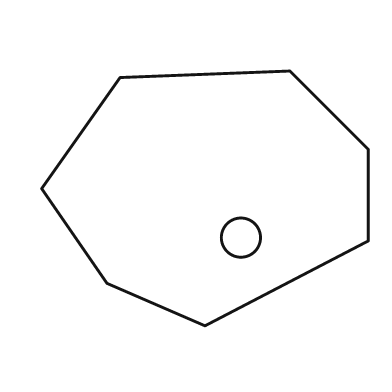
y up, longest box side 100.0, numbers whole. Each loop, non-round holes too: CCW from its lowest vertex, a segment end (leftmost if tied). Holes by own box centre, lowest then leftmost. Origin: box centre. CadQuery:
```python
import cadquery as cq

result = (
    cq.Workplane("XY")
    .moveTo(0.0, -39.0)
    .lineTo(50.0, -13.0)
    .lineTo(50.0, 15.0)
    .lineTo(26.0, 39.0)
    .lineTo(-26.0, 37.0)
    .lineTo(-50.0, 3.0)
    .lineTo(-30.0, -26.0)
    .close()
    .moveTo(11.0, -12.0)
    .circle(6.0)
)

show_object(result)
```